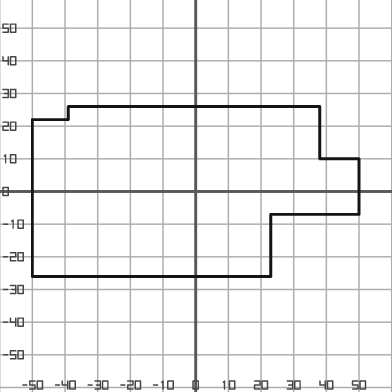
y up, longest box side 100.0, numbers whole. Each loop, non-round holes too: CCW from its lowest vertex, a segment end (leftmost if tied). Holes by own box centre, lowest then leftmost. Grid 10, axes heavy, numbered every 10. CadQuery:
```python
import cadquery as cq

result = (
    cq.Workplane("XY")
    .moveTo(-50.0, -26.0)
    .lineTo(23.0, -26.0)
    .lineTo(23.0, -7.0)
    .lineTo(50.0, -7.0)
    .lineTo(50.0, 10.0)
    .lineTo(38.0, 10.0)
    .lineTo(38.0, 26.0)
    .lineTo(-39.0, 26.0)
    .lineTo(-39.0, 22.0)
    .lineTo(-50.0, 22.0)
    .close()
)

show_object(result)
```